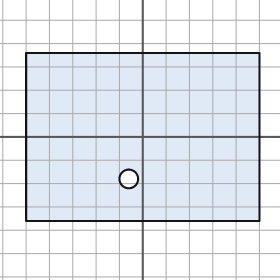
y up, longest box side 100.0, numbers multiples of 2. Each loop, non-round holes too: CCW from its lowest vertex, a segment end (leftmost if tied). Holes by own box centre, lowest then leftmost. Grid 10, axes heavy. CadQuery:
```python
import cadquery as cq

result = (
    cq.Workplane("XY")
    .moveTo(-50.0, -36.0)
    .lineTo(50.0, -36.0)
    .lineTo(50.0, 36.0)
    .lineTo(-50.0, 36.0)
    .close()
    .moveTo(-6.0, -18.0)
    .circle(4.0)
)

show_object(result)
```